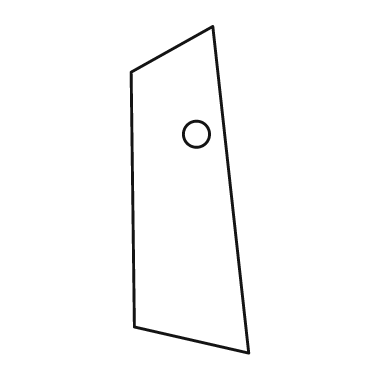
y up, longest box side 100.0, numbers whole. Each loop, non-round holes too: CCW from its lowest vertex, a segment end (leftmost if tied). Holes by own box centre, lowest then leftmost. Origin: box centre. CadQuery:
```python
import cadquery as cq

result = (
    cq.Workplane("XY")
    .moveTo(18.0, -50.0)
    .lineTo(7.0, 50.0)
    .lineTo(-18.0, 36.0)
    .lineTo(-17.0, -42.0)
    .close()
    .moveTo(2.0, 17.0)
    .circle(4.0)
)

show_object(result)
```